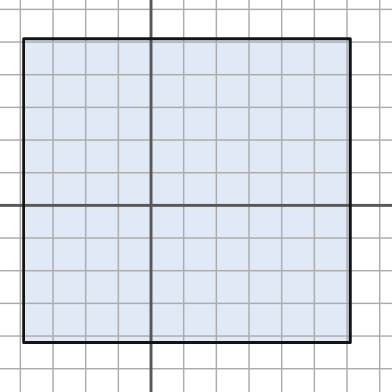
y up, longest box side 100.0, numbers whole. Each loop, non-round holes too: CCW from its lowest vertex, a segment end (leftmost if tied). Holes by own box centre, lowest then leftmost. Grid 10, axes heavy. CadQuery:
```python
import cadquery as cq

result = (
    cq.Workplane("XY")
    .moveTo(-39.0, -42.0)
    .lineTo(61.0, -42.0)
    .lineTo(61.0, 51.0)
    .lineTo(-39.0, 51.0)
    .close()
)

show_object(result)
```